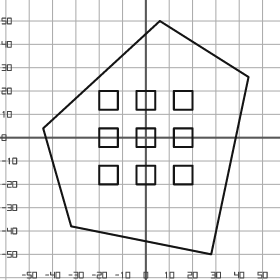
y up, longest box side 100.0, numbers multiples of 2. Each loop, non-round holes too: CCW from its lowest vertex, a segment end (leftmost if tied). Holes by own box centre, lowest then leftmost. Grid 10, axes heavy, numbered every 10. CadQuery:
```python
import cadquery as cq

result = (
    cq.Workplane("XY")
    .moveTo(28.0, -50.0)
    .lineTo(44.0, 26.0)
    .lineTo(6.0, 50.0)
    .lineTo(-44.0, 4.0)
    .lineTo(-32.0, -38.0)
    .close()
    .moveTo(-20.0, -20.0)
    .lineTo(-12.0, -20.0)
    .lineTo(-12.0, -12.0)
    .lineTo(-20.0, -12.0)
    .close()
    .moveTo(-4.0, -20.0)
    .lineTo(4.0, -20.0)
    .lineTo(4.0, -12.0)
    .lineTo(-4.0, -12.0)
    .close()
    .moveTo(12.0, -20.0)
    .lineTo(20.0, -20.0)
    .lineTo(20.0, -12.0)
    .lineTo(12.0, -12.0)
    .close()
    .moveTo(-20.0, -4.0)
    .lineTo(-12.0, -4.0)
    .lineTo(-12.0, 4.0)
    .lineTo(-20.0, 4.0)
    .close()
    .moveTo(-4.0, -4.0)
    .lineTo(4.0, -4.0)
    .lineTo(4.0, 4.0)
    .lineTo(-4.0, 4.0)
    .close()
    .moveTo(12.0, -4.0)
    .lineTo(20.0, -4.0)
    .lineTo(20.0, 4.0)
    .lineTo(12.0, 4.0)
    .close()
    .moveTo(-20.0, 12.0)
    .lineTo(-12.0, 12.0)
    .lineTo(-12.0, 20.0)
    .lineTo(-20.0, 20.0)
    .close()
    .moveTo(-4.0, 12.0)
    .lineTo(4.0, 12.0)
    .lineTo(4.0, 20.0)
    .lineTo(-4.0, 20.0)
    .close()
    .moveTo(12.0, 12.0)
    .lineTo(20.0, 12.0)
    .lineTo(20.0, 20.0)
    .lineTo(12.0, 20.0)
    .close()
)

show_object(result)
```